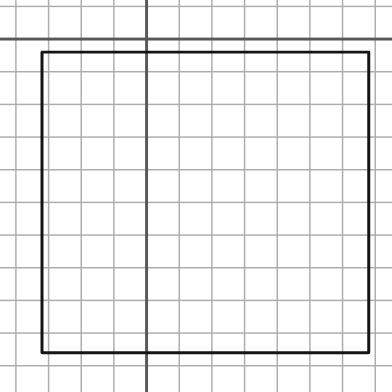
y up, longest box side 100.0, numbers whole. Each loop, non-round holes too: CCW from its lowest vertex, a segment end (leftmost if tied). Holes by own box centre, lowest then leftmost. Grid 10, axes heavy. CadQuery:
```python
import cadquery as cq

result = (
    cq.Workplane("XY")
    .moveTo(-32.0, -96.0)
    .lineTo(68.0, -96.0)
    .lineTo(68.0, -4.0)
    .lineTo(-32.0, -4.0)
    .close()
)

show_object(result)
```